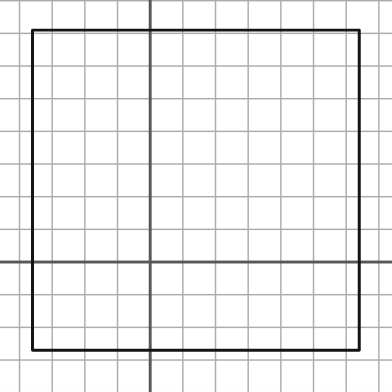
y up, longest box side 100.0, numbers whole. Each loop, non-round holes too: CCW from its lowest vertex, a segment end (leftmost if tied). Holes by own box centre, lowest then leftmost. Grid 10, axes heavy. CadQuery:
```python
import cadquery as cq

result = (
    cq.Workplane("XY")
    .moveTo(-36.0, -27.0)
    .lineTo(64.0, -27.0)
    .lineTo(64.0, 71.0)
    .lineTo(-36.0, 71.0)
    .close()
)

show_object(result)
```